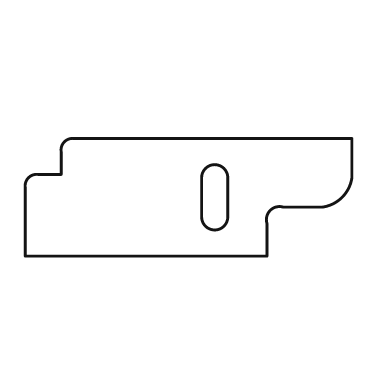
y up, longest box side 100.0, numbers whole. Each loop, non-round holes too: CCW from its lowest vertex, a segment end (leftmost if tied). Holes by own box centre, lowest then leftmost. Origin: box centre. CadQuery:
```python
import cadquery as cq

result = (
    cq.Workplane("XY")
    .moveTo(-50.0, -18.0)
    .lineTo(24.0, -18.0)
    .lineTo(24.0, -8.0)
    .threePointArc((25.0, -4.0), (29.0, -3.0))
    .lineTo(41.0, -3.0)
    .threePointArc((47.0, 0.0), (50.0, 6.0))
    .lineTo(50.0, 18.0)
    .lineTo(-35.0, 18.0)
    .threePointArc((-38.0, 17.0), (-39.0, 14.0))
    .lineTo(-39.0, 7.0)
    .lineTo(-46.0, 7.0)
    .threePointArc((-49.0, 6.0), (-50.0, 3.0))
    .close()
    .moveTo(4.0, -6.0)
    .threePointArc((8.0, -10.0), (12.0, -6.0))
    .lineTo(12.0, 6.0)
    .threePointArc((8.0, 10.0), (4.0, 6.0))
    .close()
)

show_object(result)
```